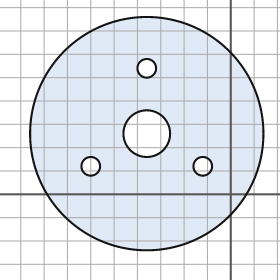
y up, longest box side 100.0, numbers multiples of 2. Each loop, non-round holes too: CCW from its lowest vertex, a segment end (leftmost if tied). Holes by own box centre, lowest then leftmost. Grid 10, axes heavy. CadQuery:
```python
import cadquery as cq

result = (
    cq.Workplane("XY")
    .moveTo(-36.0, 26.0)
    .circle(50.0)
    .moveTo(-60.0, 12.0)
    .circle(4.0)
    .moveTo(-12.0, 12.0)
    .circle(4.0)
    .moveTo(-36.0, 26.0)
    .circle(10.0)
    .moveTo(-36.0, 54.0)
    .circle(4.0)
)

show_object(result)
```